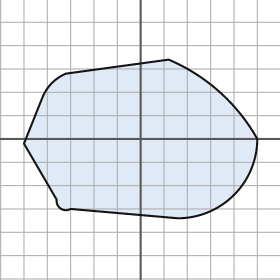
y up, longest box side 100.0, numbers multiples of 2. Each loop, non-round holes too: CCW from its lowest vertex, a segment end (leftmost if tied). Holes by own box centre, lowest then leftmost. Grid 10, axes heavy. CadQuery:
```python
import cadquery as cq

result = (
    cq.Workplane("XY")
    .moveTo(16.0, -34.0)
    .threePointArc((40.0, -24.0), (50.0, 0.0))
    .threePointArc((34.0, 20.0), (12.0, 34.0))
    .lineTo(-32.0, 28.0)
    .threePointArc((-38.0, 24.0), (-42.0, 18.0))
    .lineTo(-50.0, -2.0)
    .lineTo(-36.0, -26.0)
    .threePointArc((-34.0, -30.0), (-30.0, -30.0))
    .close()
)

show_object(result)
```